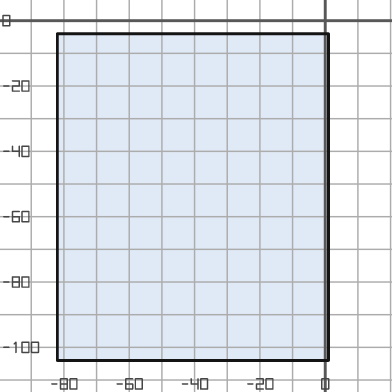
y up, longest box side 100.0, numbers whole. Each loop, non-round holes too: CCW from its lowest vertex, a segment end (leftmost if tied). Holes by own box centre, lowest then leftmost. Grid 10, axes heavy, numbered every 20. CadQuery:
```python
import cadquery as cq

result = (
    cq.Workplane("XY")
    .moveTo(-82.0, -104.0)
    .lineTo(1.0, -104.0)
    .lineTo(1.0, -4.0)
    .lineTo(-82.0, -4.0)
    .close()
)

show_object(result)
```